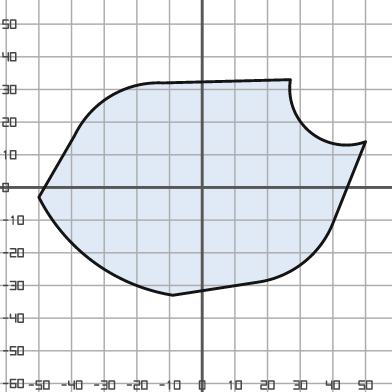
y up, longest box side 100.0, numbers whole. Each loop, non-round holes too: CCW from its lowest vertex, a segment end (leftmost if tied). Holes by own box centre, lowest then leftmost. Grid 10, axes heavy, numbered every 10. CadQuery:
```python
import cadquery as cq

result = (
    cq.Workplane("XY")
    .moveTo(-9.0, -33.0)
    .lineTo(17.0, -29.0)
    .threePointArc((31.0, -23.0), (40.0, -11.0))
    .lineTo(50.0, 14.0)
    .threePointArc((33.0, 17.0), (27.0, 33.0))
    .lineTo(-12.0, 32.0)
    .threePointArc((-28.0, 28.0), (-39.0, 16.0))
    .lineTo(-50.0, -3.0)
    .threePointArc((-33.0, -23.0), (-9.0, -33.0))
    .close()
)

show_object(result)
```